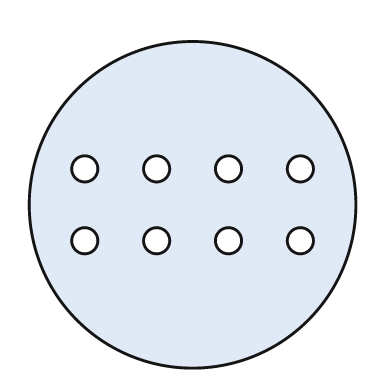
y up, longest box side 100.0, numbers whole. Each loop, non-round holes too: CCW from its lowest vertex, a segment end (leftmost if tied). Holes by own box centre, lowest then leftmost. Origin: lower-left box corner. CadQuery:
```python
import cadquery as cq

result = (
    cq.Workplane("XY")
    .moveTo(50.0, 50.0)
    .circle(50.0)
    .moveTo(17.0, 39.0)
    .circle(4.0)
    .moveTo(39.0, 39.0)
    .circle(4.0)
    .moveTo(61.0, 39.0)
    .circle(4.0)
    .moveTo(83.0, 39.0)
    .circle(4.0)
    .moveTo(17.0, 61.0)
    .circle(4.0)
    .moveTo(39.0, 61.0)
    .circle(4.0)
    .moveTo(61.0, 61.0)
    .circle(4.0)
    .moveTo(83.0, 61.0)
    .circle(4.0)
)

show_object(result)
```